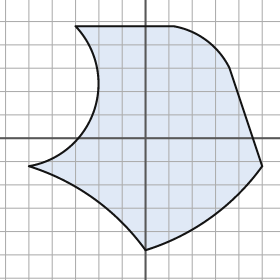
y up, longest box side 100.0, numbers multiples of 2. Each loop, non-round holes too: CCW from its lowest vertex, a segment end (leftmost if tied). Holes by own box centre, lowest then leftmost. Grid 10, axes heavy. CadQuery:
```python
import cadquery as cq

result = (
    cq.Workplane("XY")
    .moveTo(0.0, -48.0)
    .threePointArc((28.0, -34.0), (50.0, -12.0))
    .lineTo(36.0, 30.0)
    .threePointArc((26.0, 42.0), (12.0, 48.0))
    .lineTo(-30.0, 48.0)
    .threePointArc((-22.0, 12.0), (-50.0, -12.0))
    .threePointArc((-22.0, -26.0), (0.0, -48.0))
    .close()
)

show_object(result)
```